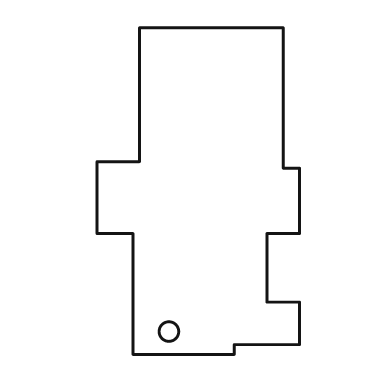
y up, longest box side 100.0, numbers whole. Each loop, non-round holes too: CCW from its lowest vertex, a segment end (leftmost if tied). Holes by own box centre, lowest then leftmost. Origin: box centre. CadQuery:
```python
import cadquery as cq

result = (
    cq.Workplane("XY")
    .moveTo(-20.0, -50.0)
    .lineTo(11.0, -50.0)
    .lineTo(11.0, -47.0)
    .lineTo(31.0, -47.0)
    .lineTo(31.0, -34.0)
    .lineTo(21.0, -34.0)
    .lineTo(21.0, -13.0)
    .lineTo(31.0, -13.0)
    .lineTo(31.0, 7.0)
    .lineTo(26.0, 7.0)
    .lineTo(26.0, 50.0)
    .lineTo(-18.0, 50.0)
    .lineTo(-18.0, 9.0)
    .lineTo(-31.0, 9.0)
    .lineTo(-31.0, -13.0)
    .lineTo(-20.0, -13.0)
    .close()
    .moveTo(-9.0, -43.0)
    .circle(3.0)
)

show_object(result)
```